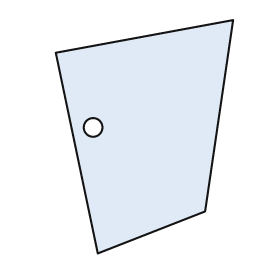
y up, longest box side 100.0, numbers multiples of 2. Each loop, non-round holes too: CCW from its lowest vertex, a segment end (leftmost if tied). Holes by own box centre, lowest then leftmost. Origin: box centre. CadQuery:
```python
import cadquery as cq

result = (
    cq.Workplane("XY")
    .moveTo(-20.0, -50.0)
    .lineTo(26.0, -32.0)
    .lineTo(38.0, 50.0)
    .lineTo(-38.0, 36.0)
    .close()
    .moveTo(-22.0, 4.0)
    .circle(4.0)
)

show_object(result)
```